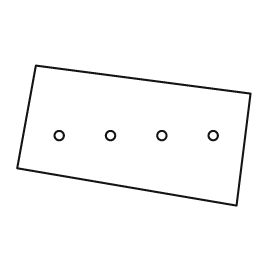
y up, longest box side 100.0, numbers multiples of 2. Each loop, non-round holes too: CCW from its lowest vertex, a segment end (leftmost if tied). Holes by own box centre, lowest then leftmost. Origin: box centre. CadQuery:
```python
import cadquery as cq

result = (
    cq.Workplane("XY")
    .moveTo(44.0, -30.0)
    .lineTo(50.0, 18.0)
    .lineTo(-42.0, 30.0)
    .lineTo(-50.0, -14.0)
    .close()
    .moveTo(-32.0, 0.0)
    .circle(2.0)
    .moveTo(-10.0, 0.0)
    .circle(2.0)
    .moveTo(12.0, 0.0)
    .circle(2.0)
    .moveTo(34.0, 0.0)
    .circle(2.0)
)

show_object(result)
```